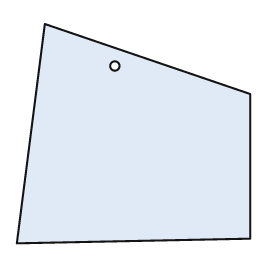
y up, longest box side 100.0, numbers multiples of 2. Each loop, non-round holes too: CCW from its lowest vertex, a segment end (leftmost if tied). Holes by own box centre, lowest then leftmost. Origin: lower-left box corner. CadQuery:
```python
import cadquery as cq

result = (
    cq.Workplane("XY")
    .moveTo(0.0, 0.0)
    .lineTo(100.0, 2.0)
    .lineTo(100.0, 64.0)
    .lineTo(12.0, 94.0)
    .close()
    .moveTo(42.0, 76.0)
    .circle(2.0)
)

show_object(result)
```